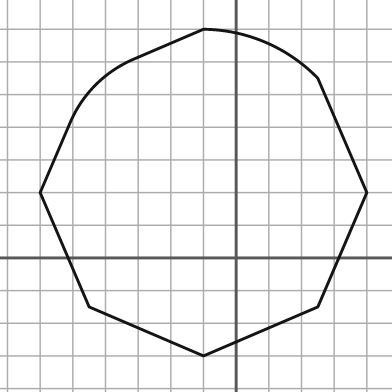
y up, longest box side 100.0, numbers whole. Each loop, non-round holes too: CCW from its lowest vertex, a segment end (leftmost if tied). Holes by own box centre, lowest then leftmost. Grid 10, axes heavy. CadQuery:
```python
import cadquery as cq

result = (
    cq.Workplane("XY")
    .moveTo(-10.0, -30.0)
    .lineTo(25.0, -15.0)
    .lineTo(40.0, 20.0)
    .lineTo(25.0, 55.0)
    .threePointArc((9.0, 66.0), (-10.0, 70.0))
    .lineTo(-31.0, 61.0)
    .threePointArc((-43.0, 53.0), (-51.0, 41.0))
    .lineTo(-60.0, 20.0)
    .lineTo(-45.0, -15.0)
    .close()
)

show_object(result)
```